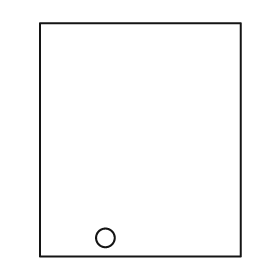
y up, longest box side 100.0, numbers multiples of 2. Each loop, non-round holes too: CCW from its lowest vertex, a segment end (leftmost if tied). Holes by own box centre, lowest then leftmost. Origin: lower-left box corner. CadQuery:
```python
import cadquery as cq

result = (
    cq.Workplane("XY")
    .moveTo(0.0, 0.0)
    .lineTo(86.0, 0.0)
    .lineTo(86.0, 100.0)
    .lineTo(0.0, 100.0)
    .close()
    .moveTo(28.0, 8.0)
    .circle(4.0)
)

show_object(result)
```